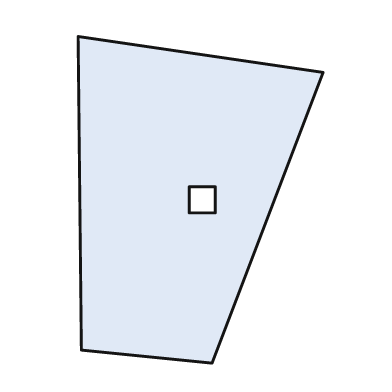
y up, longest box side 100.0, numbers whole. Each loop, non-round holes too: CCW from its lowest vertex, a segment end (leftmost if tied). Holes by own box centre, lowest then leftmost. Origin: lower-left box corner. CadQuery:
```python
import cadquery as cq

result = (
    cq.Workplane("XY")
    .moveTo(41.0, 0.0)
    .lineTo(75.0, 89.0)
    .lineTo(0.0, 100.0)
    .lineTo(1.0, 4.0)
    .close()
    .moveTo(34.0, 46.0)
    .lineTo(42.0, 46.0)
    .lineTo(42.0, 54.0)
    .lineTo(34.0, 54.0)
    .close()
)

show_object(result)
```